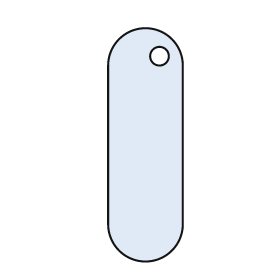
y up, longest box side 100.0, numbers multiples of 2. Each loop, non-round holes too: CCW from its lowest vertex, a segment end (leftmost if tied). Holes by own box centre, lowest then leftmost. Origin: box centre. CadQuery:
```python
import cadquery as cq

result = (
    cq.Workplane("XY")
    .moveTo(-16.0, -34.0)
    .threePointArc((0.0, -50.0), (16.0, -34.0))
    .lineTo(16.0, 34.0)
    .threePointArc((0.0, 50.0), (-16.0, 34.0))
    .close()
    .moveTo(6.0, 38.0)
    .circle(4.0)
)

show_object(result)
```